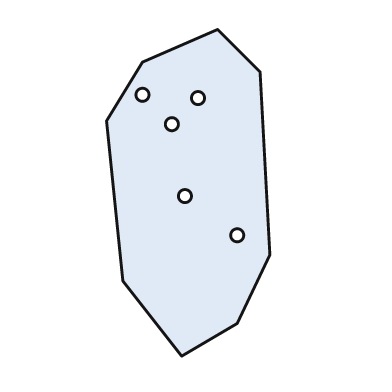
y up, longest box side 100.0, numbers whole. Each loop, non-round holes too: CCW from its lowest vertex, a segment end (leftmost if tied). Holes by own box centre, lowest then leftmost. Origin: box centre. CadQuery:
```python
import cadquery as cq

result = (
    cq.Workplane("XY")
    .moveTo(-2.0, -50.0)
    .lineTo(15.0, -40.0)
    .lineTo(25.0, -19.0)
    .lineTo(22.0, 37.0)
    .lineTo(9.0, 50.0)
    .lineTo(-14.0, 40.0)
    .lineTo(-25.0, 22.0)
    .lineTo(-20.0, -27.0)
    .close()
    .moveTo(15.0, -13.0)
    .circle(2.0)
    .moveTo(-1.0, -1.0)
    .circle(2.0)
    .moveTo(-5.0, 21.0)
    .circle(2.0)
    .moveTo(3.0, 29.0)
    .circle(2.0)
    .moveTo(-14.0, 30.0)
    .circle(2.0)
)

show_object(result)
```